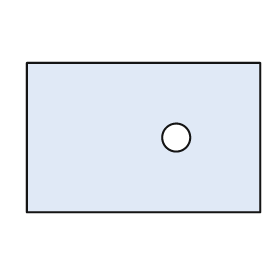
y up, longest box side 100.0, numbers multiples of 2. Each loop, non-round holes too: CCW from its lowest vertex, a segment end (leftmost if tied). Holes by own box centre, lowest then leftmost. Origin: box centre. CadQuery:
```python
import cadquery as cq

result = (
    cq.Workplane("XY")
    .moveTo(-50.0, -32.0)
    .lineTo(50.0, -32.0)
    .lineTo(50.0, 32.0)
    .lineTo(-50.0, 32.0)
    .close()
    .moveTo(14.0, 0.0)
    .circle(6.0)
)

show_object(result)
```